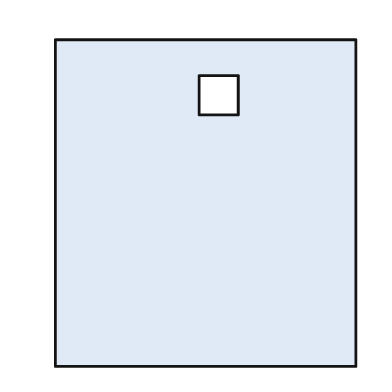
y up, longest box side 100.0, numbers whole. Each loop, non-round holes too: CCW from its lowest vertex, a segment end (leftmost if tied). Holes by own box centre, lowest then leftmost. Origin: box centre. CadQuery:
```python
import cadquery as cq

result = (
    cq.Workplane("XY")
    .moveTo(-46.0, -50.0)
    .lineTo(46.0, -50.0)
    .lineTo(46.0, 50.0)
    .lineTo(-46.0, 50.0)
    .close()
    .moveTo(-2.0, 27.0)
    .lineTo(10.0, 27.0)
    .lineTo(10.0, 39.0)
    .lineTo(-2.0, 39.0)
    .close()
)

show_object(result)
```